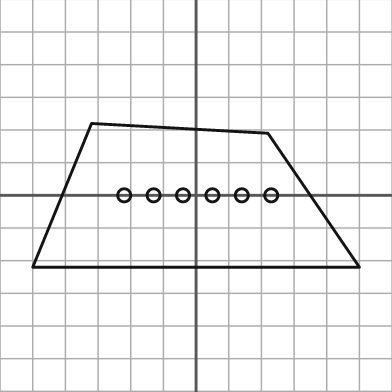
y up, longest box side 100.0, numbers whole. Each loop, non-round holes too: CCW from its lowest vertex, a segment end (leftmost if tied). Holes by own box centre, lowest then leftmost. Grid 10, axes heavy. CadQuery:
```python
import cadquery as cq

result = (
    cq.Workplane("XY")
    .moveTo(-50.0, -22.0)
    .lineTo(50.0, -22.0)
    .lineTo(22.0, 19.0)
    .lineTo(-32.0, 22.0)
    .close()
    .moveTo(-22.0, 0.0)
    .circle(2.0)
    .moveTo(-13.0, 0.0)
    .circle(2.0)
    .moveTo(-4.0, 0.0)
    .circle(2.0)
    .moveTo(5.0, 0.0)
    .circle(2.0)
    .moveTo(14.0, 0.0)
    .circle(2.0)
    .moveTo(23.0, 0.0)
    .circle(2.0)
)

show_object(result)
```